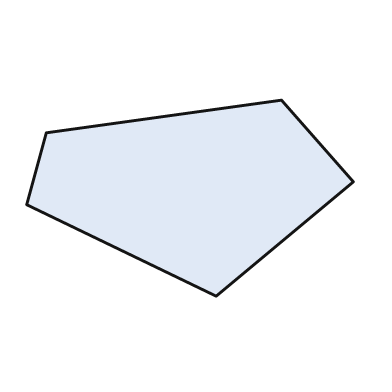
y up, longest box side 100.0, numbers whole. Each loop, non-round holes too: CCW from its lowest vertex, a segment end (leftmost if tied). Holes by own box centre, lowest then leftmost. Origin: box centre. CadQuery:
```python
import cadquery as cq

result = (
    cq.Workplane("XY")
    .moveTo(8.0, -30.0)
    .lineTo(50.0, 5.0)
    .lineTo(28.0, 30.0)
    .lineTo(-44.0, 20.0)
    .lineTo(-50.0, -2.0)
    .close()
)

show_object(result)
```